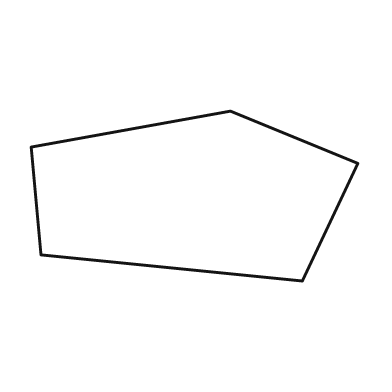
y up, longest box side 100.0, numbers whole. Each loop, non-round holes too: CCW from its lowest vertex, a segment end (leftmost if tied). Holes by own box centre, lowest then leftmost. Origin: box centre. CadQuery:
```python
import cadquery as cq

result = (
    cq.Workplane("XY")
    .moveTo(33.0, -26.0)
    .lineTo(50.0, 10.0)
    .lineTo(11.0, 26.0)
    .lineTo(-50.0, 15.0)
    .lineTo(-47.0, -18.0)
    .close()
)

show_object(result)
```